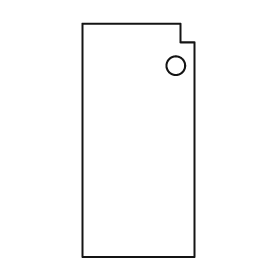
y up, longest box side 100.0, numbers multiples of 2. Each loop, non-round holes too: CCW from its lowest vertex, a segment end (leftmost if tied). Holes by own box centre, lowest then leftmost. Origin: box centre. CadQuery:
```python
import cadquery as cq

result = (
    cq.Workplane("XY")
    .moveTo(-24.0, -50.0)
    .lineTo(24.0, -50.0)
    .lineTo(24.0, 42.0)
    .lineTo(18.0, 42.0)
    .lineTo(18.0, 50.0)
    .lineTo(-24.0, 50.0)
    .close()
    .moveTo(16.0, 32.0)
    .circle(4.0)
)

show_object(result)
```